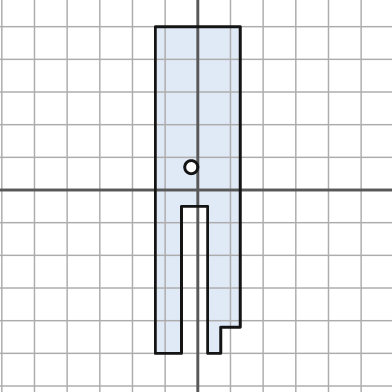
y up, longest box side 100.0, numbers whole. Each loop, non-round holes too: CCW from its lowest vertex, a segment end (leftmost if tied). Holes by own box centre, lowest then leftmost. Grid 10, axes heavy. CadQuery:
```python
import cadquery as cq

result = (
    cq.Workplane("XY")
    .moveTo(-13.0, -50.0)
    .lineTo(-5.0, -50.0)
    .lineTo(-5.0, -5.0)
    .lineTo(3.0, -5.0)
    .lineTo(3.0, -50.0)
    .lineTo(7.0, -50.0)
    .lineTo(7.0, -42.0)
    .lineTo(13.0, -42.0)
    .lineTo(13.0, 50.0)
    .lineTo(-13.0, 50.0)
    .close()
    .moveTo(-2.0, 7.0)
    .circle(2.0)
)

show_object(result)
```